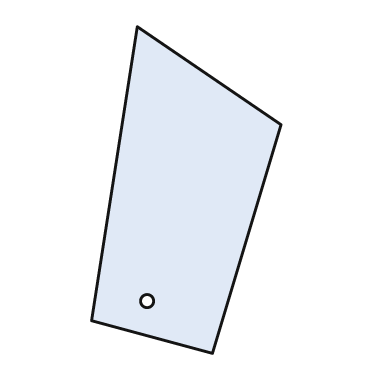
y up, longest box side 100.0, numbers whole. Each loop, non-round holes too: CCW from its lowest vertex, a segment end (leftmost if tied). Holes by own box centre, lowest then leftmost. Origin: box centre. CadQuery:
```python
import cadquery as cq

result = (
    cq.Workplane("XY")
    .moveTo(8.0, -50.0)
    .lineTo(29.0, 20.0)
    .lineTo(-15.0, 50.0)
    .lineTo(-29.0, -40.0)
    .close()
    .moveTo(-12.0, -34.0)
    .circle(2.0)
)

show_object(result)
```